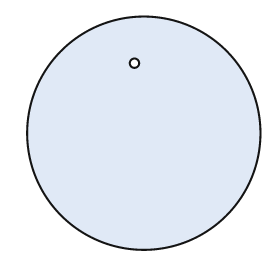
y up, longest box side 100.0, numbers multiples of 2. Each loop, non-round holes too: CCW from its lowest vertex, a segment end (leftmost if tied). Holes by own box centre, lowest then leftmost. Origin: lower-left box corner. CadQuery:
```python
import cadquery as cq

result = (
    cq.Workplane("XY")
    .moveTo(50.0, 50.0)
    .circle(50.0)
    .moveTo(46.0, 80.0)
    .circle(2.0)
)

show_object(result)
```